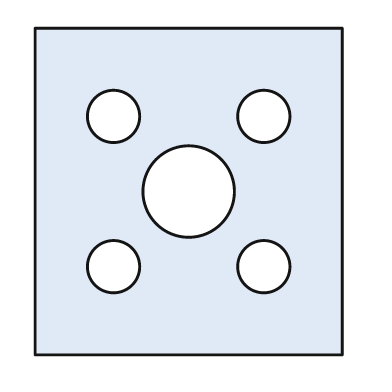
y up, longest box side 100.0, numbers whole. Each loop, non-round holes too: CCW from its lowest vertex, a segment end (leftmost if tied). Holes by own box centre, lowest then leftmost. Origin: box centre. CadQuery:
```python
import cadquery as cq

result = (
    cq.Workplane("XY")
    .moveTo(-47.0, -50.0)
    .lineTo(47.0, -50.0)
    .lineTo(47.0, 50.0)
    .lineTo(-47.0, 50.0)
    .close()
    .moveTo(-23.0, -23.0)
    .circle(8.0)
    .moveTo(23.0, -23.0)
    .circle(8.0)
    .moveTo(0.0, 0.0)
    .circle(14.0)
    .moveTo(-23.0, 23.0)
    .circle(8.0)
    .moveTo(23.0, 23.0)
    .circle(8.0)
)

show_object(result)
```